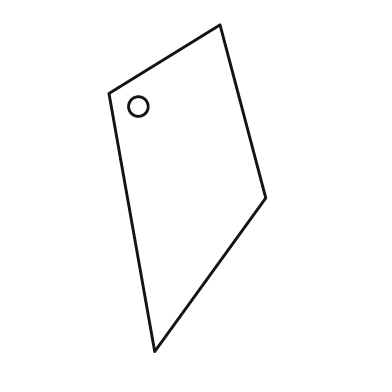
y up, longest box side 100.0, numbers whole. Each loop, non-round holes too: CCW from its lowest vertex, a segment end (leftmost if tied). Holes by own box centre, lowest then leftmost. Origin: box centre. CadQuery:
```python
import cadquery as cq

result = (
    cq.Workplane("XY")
    .moveTo(-10.0, -50.0)
    .lineTo(24.0, -3.0)
    .lineTo(10.0, 50.0)
    .lineTo(-24.0, 29.0)
    .close()
    .moveTo(-15.0, 25.0)
    .circle(3.0)
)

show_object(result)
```